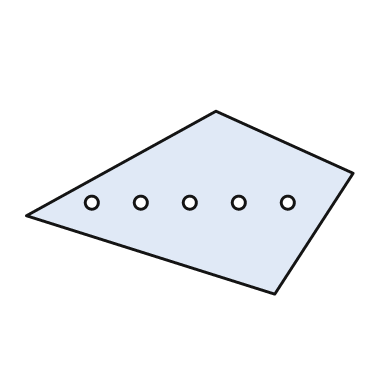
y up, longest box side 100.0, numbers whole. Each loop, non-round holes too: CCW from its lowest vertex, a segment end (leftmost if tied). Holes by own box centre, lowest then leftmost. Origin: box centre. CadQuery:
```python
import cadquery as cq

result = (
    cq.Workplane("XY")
    .moveTo(26.0, -28.0)
    .lineTo(50.0, 9.0)
    .lineTo(8.0, 28.0)
    .lineTo(-50.0, -4.0)
    .close()
    .moveTo(-30.0, 0.0)
    .circle(2.0)
    .moveTo(-15.0, 0.0)
    .circle(2.0)
    .moveTo(0.0, 0.0)
    .circle(2.0)
    .moveTo(15.0, 0.0)
    .circle(2.0)
    .moveTo(30.0, 0.0)
    .circle(2.0)
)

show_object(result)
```